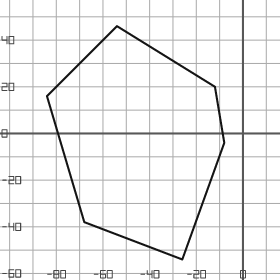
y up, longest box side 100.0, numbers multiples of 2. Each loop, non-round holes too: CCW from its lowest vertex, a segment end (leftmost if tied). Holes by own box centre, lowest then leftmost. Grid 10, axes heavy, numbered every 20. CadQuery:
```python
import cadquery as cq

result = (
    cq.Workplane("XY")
    .moveTo(-26.0, -54.0)
    .lineTo(-8.0, -4.0)
    .lineTo(-12.0, 20.0)
    .lineTo(-54.0, 46.0)
    .lineTo(-84.0, 16.0)
    .lineTo(-68.0, -38.0)
    .close()
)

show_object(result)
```